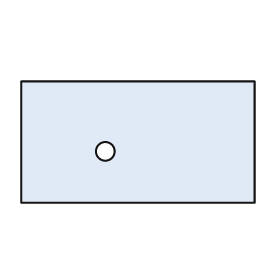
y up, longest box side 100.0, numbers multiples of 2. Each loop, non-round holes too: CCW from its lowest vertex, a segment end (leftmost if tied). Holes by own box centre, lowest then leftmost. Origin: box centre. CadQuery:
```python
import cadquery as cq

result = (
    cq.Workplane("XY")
    .moveTo(-50.0, -26.0)
    .lineTo(50.0, -26.0)
    .lineTo(50.0, 26.0)
    .lineTo(-50.0, 26.0)
    .close()
    .moveTo(-14.0, -4.0)
    .circle(4.0)
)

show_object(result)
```